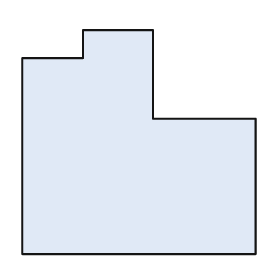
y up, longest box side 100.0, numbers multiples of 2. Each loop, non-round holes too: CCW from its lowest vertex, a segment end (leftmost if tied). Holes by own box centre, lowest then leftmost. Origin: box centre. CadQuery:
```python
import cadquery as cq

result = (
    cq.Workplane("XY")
    .moveTo(-50.0, -48.0)
    .lineTo(50.0, -48.0)
    .lineTo(50.0, 10.0)
    .lineTo(6.0, 10.0)
    .lineTo(6.0, 48.0)
    .lineTo(-24.0, 48.0)
    .lineTo(-24.0, 36.0)
    .lineTo(-50.0, 36.0)
    .close()
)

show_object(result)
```